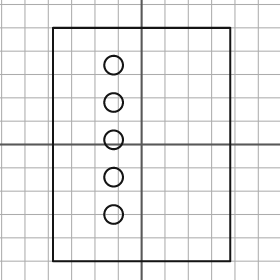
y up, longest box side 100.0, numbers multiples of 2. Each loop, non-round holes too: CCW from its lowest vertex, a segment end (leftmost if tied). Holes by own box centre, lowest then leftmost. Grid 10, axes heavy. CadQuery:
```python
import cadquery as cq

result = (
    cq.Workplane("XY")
    .moveTo(-38.0, -50.0)
    .lineTo(38.0, -50.0)
    .lineTo(38.0, 50.0)
    .lineTo(-38.0, 50.0)
    .close()
    .moveTo(-12.0, -30.0)
    .circle(4.0)
    .moveTo(-12.0, -14.0)
    .circle(4.0)
    .moveTo(-12.0, 2.0)
    .circle(4.0)
    .moveTo(-12.0, 18.0)
    .circle(4.0)
    .moveTo(-12.0, 34.0)
    .circle(4.0)
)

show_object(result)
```